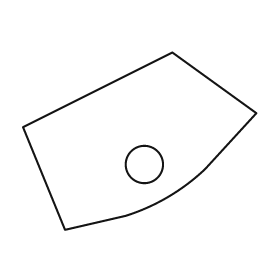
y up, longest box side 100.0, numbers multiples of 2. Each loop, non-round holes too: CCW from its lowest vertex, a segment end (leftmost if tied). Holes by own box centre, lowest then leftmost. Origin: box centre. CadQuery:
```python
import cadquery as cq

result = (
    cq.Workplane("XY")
    .moveTo(-32.0, -38.0)
    .lineTo(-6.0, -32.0)
    .threePointArc((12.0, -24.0), (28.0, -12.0))
    .lineTo(50.0, 12.0)
    .lineTo(14.0, 38.0)
    .lineTo(-50.0, 6.0)
    .close()
    .moveTo(2.0, -10.0)
    .circle(8.0)
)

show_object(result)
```